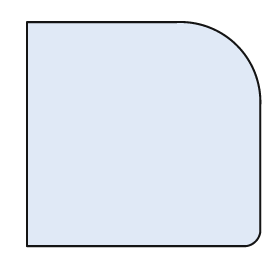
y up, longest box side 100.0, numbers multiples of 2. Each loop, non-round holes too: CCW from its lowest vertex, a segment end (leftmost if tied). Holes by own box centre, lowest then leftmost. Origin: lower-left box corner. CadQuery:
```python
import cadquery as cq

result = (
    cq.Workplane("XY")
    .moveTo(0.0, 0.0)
    .lineTo(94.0, 0.0)
    .threePointArc((98.0, 2.0), (100.0, 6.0))
    .lineTo(100.0, 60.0)
    .threePointArc((90.0, 86.0), (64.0, 96.0))
    .lineTo(0.0, 96.0)
    .close()
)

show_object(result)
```